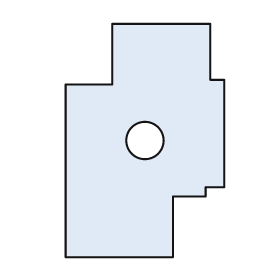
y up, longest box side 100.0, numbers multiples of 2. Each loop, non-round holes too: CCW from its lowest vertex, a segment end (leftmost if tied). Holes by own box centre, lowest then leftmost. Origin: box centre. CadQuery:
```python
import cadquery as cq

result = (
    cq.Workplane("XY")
    .moveTo(-34.0, -50.0)
    .lineTo(12.0, -50.0)
    .lineTo(12.0, -24.0)
    .lineTo(26.0, -24.0)
    .lineTo(26.0, -20.0)
    .lineTo(34.0, -20.0)
    .lineTo(34.0, 26.0)
    .lineTo(28.0, 26.0)
    .lineTo(28.0, 50.0)
    .lineTo(-14.0, 50.0)
    .lineTo(-14.0, 24.0)
    .lineTo(-34.0, 24.0)
    .close()
    .moveTo(0.0, 0.0)
    .circle(8.0)
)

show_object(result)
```